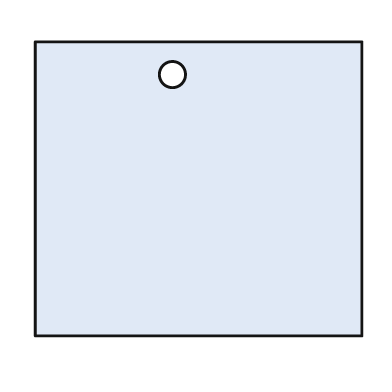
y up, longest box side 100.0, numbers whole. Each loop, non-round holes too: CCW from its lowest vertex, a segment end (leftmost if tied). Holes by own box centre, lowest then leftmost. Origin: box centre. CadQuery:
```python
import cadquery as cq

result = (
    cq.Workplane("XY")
    .moveTo(-50.0, -45.0)
    .lineTo(50.0, -45.0)
    .lineTo(50.0, 45.0)
    .lineTo(-50.0, 45.0)
    .close()
    .moveTo(-8.0, 35.0)
    .circle(4.0)
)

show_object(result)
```